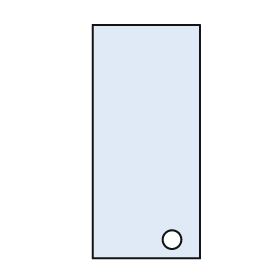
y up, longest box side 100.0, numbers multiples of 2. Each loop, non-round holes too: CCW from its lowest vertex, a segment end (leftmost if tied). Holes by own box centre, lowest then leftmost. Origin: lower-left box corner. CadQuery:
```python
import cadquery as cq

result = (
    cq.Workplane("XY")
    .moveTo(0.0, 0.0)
    .lineTo(46.0, 0.0)
    .lineTo(46.0, 100.0)
    .lineTo(0.0, 100.0)
    .close()
    .moveTo(34.0, 8.0)
    .circle(4.0)
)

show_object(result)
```